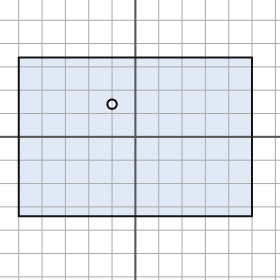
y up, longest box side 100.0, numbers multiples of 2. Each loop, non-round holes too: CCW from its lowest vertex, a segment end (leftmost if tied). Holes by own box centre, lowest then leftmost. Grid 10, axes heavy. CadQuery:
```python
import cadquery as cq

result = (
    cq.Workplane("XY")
    .moveTo(-50.0, -34.0)
    .lineTo(50.0, -34.0)
    .lineTo(50.0, 34.0)
    .lineTo(-50.0, 34.0)
    .close()
    .moveTo(-10.0, 14.0)
    .circle(2.0)
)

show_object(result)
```